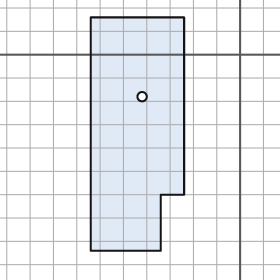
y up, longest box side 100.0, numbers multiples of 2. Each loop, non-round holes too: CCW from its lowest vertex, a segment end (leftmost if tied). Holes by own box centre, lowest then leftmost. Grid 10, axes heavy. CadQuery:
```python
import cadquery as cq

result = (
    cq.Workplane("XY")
    .moveTo(-64.0, -84.0)
    .lineTo(-34.0, -84.0)
    .lineTo(-34.0, -60.0)
    .lineTo(-24.0, -60.0)
    .lineTo(-24.0, 16.0)
    .lineTo(-64.0, 16.0)
    .close()
    .moveTo(-42.0, -18.0)
    .circle(2.0)
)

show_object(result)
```